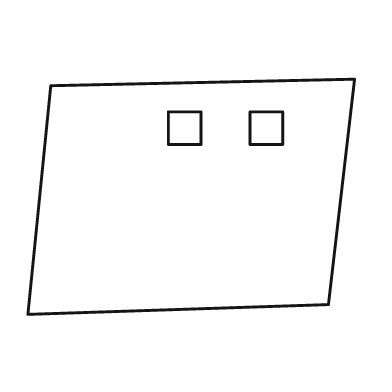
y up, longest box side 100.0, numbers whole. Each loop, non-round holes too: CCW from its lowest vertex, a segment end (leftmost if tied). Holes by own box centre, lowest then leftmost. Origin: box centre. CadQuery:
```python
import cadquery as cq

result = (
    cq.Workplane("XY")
    .moveTo(-50.0, -36.0)
    .lineTo(42.0, -33.0)
    .lineTo(50.0, 36.0)
    .lineTo(-43.0, 34.0)
    .close()
    .moveTo(-7.0, 16.0)
    .lineTo(3.0, 16.0)
    .lineTo(3.0, 26.0)
    .lineTo(-7.0, 26.0)
    .close()
    .moveTo(18.0, 16.0)
    .lineTo(28.0, 16.0)
    .lineTo(28.0, 26.0)
    .lineTo(18.0, 26.0)
    .close()
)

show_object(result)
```